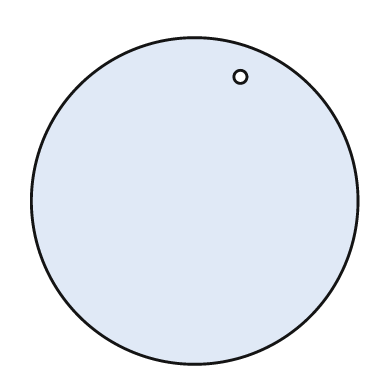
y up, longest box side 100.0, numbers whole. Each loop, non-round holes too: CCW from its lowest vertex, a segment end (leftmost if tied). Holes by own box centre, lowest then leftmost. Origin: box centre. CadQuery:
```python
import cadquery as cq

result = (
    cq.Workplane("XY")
    .moveTo(0.0, 0.0)
    .circle(50.0)
    .moveTo(14.0, 38.0)
    .circle(2.0)
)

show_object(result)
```